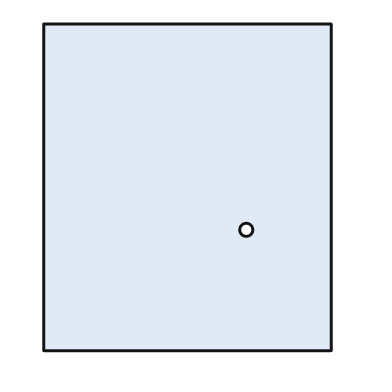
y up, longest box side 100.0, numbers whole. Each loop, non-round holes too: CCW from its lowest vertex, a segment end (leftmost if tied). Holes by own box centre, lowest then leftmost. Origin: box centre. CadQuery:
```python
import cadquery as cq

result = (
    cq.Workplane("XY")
    .moveTo(-44.0, -50.0)
    .lineTo(44.0, -50.0)
    .lineTo(44.0, 50.0)
    .lineTo(-44.0, 50.0)
    .close()
    .moveTo(18.0, -13.0)
    .circle(2.0)
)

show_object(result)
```